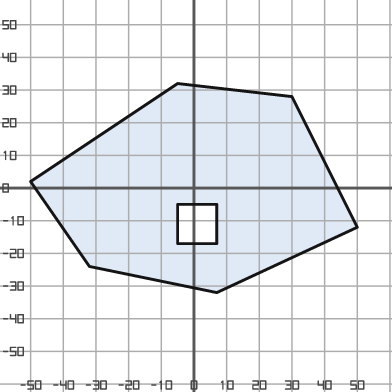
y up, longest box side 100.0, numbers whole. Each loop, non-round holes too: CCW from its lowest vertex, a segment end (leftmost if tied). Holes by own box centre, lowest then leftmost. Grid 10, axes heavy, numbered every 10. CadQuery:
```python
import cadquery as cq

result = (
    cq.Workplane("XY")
    .moveTo(7.0, -32.0)
    .lineTo(50.0, -12.0)
    .lineTo(30.0, 28.0)
    .lineTo(-5.0, 32.0)
    .lineTo(-50.0, 2.0)
    .lineTo(-32.0, -24.0)
    .close()
    .moveTo(-5.0, -17.0)
    .lineTo(7.0, -17.0)
    .lineTo(7.0, -5.0)
    .lineTo(-5.0, -5.0)
    .close()
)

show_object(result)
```